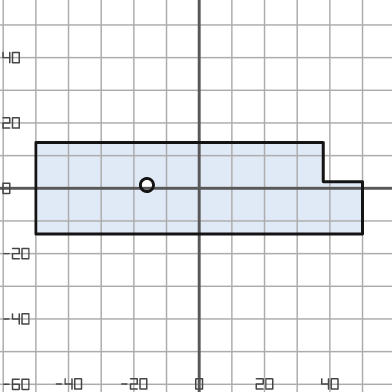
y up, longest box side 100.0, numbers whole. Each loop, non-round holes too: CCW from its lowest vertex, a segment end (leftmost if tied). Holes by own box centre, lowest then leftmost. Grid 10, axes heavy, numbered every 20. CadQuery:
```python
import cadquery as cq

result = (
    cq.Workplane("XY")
    .moveTo(-50.0, -14.0)
    .lineTo(50.0, -14.0)
    .lineTo(50.0, 2.0)
    .lineTo(38.0, 2.0)
    .lineTo(38.0, 14.0)
    .lineTo(-50.0, 14.0)
    .close()
    .moveTo(-16.0, 1.0)
    .circle(2.0)
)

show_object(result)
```